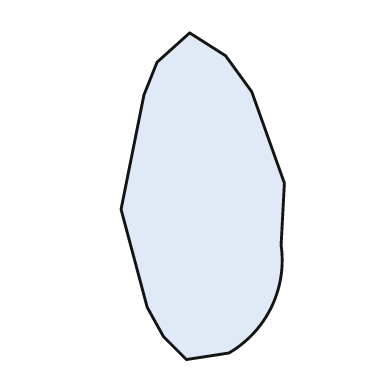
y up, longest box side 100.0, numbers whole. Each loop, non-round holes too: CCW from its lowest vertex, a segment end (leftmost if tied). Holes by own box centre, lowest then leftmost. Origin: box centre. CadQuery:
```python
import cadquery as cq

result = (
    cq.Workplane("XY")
    .moveTo(-5.0, -50.0)
    .lineTo(8.0, -48.0)
    .threePointArc((21.0, -34.0), (24.0, -15.0))
    .lineTo(25.0, 4.0)
    .lineTo(15.0, 32.0)
    .lineTo(7.0, 43.0)
    .lineTo(-4.0, 50.0)
    .lineTo(-14.0, 41.0)
    .lineTo(-18.0, 31.0)
    .lineTo(-25.0, -4.0)
    .lineTo(-17.0, -34.0)
    .lineTo(-12.0, -43.0)
    .close()
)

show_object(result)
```